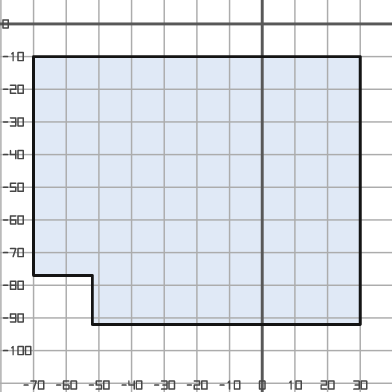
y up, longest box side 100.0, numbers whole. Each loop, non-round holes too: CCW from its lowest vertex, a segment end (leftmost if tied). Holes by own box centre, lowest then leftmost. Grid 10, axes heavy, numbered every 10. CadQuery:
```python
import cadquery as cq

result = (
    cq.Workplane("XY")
    .moveTo(-52.0, -92.0)
    .lineTo(30.0, -92.0)
    .lineTo(30.0, -10.0)
    .lineTo(-70.0, -10.0)
    .lineTo(-70.0, -77.0)
    .lineTo(-52.0, -77.0)
    .close()
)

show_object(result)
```